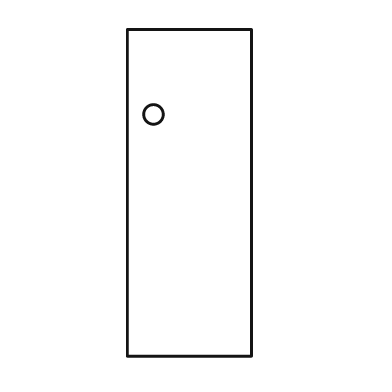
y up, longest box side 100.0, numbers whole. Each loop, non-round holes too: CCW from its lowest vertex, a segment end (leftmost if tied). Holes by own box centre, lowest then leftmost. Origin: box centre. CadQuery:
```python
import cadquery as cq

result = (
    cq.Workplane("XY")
    .moveTo(-19.0, -50.0)
    .lineTo(19.0, -50.0)
    .lineTo(19.0, 50.0)
    .lineTo(-19.0, 50.0)
    .close()
    .moveTo(-11.0, 24.0)
    .circle(3.0)
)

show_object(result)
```